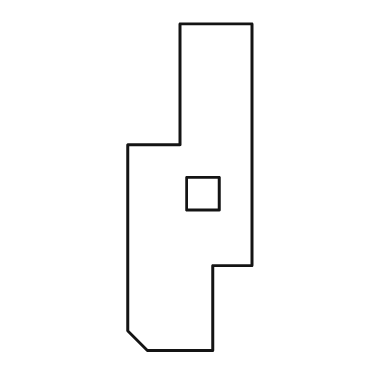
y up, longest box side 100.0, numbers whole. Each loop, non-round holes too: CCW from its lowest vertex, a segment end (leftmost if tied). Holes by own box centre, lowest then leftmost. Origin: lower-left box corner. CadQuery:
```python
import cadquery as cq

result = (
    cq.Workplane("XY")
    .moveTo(6.0, 0.0)
    .lineTo(26.0, 0.0)
    .lineTo(26.0, 26.0)
    .lineTo(38.0, 26.0)
    .lineTo(38.0, 100.0)
    .lineTo(16.0, 100.0)
    .lineTo(16.0, 63.0)
    .lineTo(0.0, 63.0)
    .lineTo(0.0, 6.0)
    .close()
    .moveTo(18.0, 43.0)
    .lineTo(28.0, 43.0)
    .lineTo(28.0, 53.0)
    .lineTo(18.0, 53.0)
    .close()
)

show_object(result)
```